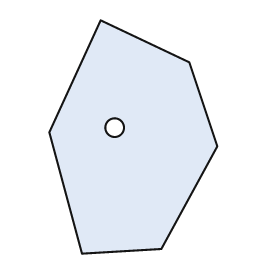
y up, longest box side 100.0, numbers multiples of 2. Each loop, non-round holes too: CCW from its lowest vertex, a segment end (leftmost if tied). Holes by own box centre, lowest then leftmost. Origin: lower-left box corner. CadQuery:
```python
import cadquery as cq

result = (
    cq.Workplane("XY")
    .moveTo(14.0, 0.0)
    .lineTo(48.0, 2.0)
    .lineTo(72.0, 46.0)
    .lineTo(60.0, 82.0)
    .lineTo(22.0, 100.0)
    .lineTo(0.0, 52.0)
    .close()
    .moveTo(28.0, 54.0)
    .circle(4.0)
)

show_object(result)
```